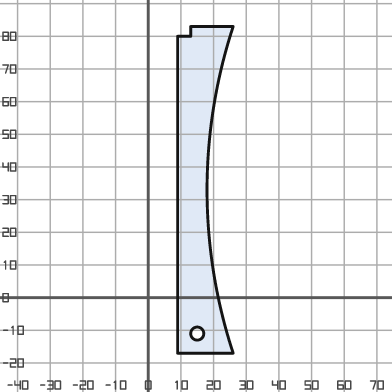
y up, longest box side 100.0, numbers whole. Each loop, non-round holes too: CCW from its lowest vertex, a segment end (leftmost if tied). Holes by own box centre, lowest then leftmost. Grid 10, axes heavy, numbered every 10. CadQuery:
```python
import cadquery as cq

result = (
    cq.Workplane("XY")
    .moveTo(9.0, -17.0)
    .lineTo(26.0, -17.0)
    .threePointArc((18.0, 33.0), (26.0, 83.0))
    .lineTo(13.0, 83.0)
    .lineTo(13.0, 80.0)
    .lineTo(9.0, 80.0)
    .close()
    .moveTo(15.0, -11.0)
    .circle(2.0)
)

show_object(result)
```